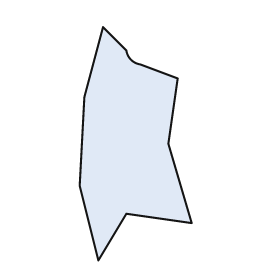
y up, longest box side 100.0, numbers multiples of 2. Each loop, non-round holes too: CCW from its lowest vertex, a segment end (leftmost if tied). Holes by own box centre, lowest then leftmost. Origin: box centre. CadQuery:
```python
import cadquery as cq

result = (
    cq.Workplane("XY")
    .moveTo(-16.0, -50.0)
    .lineTo(-4.0, -30.0)
    .lineTo(24.0, -34.0)
    .lineTo(14.0, 0.0)
    .lineTo(18.0, 28.0)
    .lineTo(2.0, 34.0)
    .threePointArc((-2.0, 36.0), (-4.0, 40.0))
    .lineTo(-14.0, 50.0)
    .lineTo(-22.0, 20.0)
    .lineTo(-24.0, -18.0)
    .close()
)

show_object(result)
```